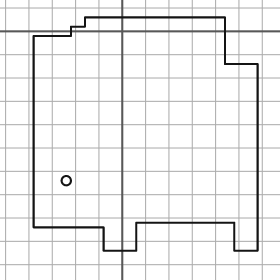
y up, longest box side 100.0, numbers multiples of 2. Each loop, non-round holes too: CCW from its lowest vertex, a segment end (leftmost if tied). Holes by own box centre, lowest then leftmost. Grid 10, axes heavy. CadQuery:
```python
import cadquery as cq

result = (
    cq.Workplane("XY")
    .moveTo(-8.0, -94.0)
    .lineTo(6.0, -94.0)
    .lineTo(6.0, -82.0)
    .lineTo(48.0, -82.0)
    .lineTo(48.0, -94.0)
    .lineTo(58.0, -94.0)
    .lineTo(58.0, -14.0)
    .lineTo(44.0, -14.0)
    .lineTo(44.0, 6.0)
    .lineTo(-16.0, 6.0)
    .lineTo(-16.0, 2.0)
    .lineTo(-22.0, 2.0)
    .lineTo(-22.0, -2.0)
    .lineTo(-38.0, -2.0)
    .lineTo(-38.0, -84.0)
    .lineTo(-8.0, -84.0)
    .close()
    .moveTo(-24.0, -64.0)
    .circle(2.0)
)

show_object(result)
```